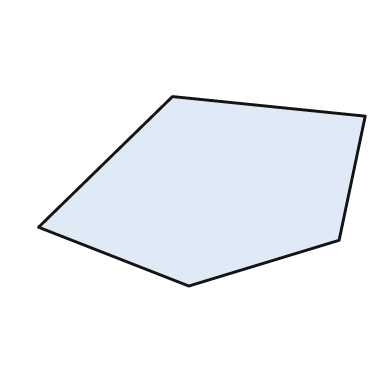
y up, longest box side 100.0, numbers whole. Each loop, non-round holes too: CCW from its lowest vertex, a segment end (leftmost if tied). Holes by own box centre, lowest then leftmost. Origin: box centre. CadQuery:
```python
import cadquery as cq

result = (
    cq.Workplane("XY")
    .moveTo(-4.0, -29.0)
    .lineTo(42.0, -15.0)
    .lineTo(50.0, 23.0)
    .lineTo(-9.0, 29.0)
    .lineTo(-50.0, -11.0)
    .close()
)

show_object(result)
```